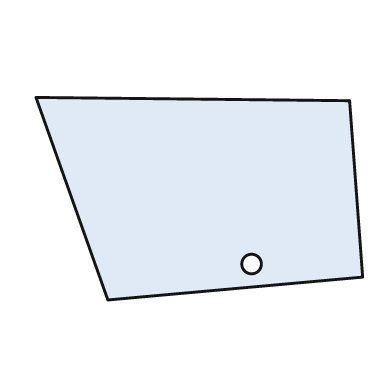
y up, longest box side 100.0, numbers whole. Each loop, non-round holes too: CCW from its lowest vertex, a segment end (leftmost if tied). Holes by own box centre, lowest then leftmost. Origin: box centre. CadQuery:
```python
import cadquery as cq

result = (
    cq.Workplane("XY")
    .moveTo(-28.0, -31.0)
    .lineTo(50.0, -24.0)
    .lineTo(46.0, 30.0)
    .lineTo(-50.0, 31.0)
    .close()
    .moveTo(16.0, -20.0)
    .circle(3.0)
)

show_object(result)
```